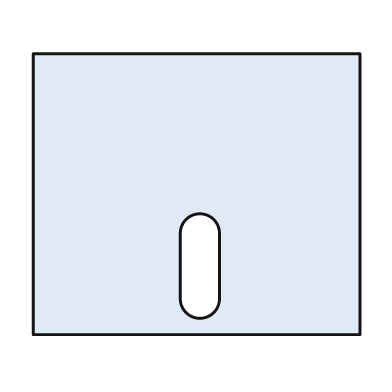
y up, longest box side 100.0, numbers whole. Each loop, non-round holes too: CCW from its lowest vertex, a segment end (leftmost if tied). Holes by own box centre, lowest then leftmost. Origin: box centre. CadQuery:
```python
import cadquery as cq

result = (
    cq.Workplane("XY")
    .moveTo(-50.0, -43.0)
    .lineTo(50.0, -43.0)
    .lineTo(50.0, 43.0)
    .lineTo(-50.0, 43.0)
    .close()
    .moveTo(-5.0, -32.0)
    .threePointArc((1.0, -38.0), (7.0, -32.0))
    .lineTo(7.0, -12.0)
    .threePointArc((1.0, -6.0), (-5.0, -12.0))
    .close()
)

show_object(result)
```